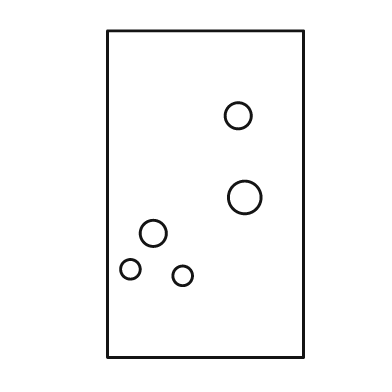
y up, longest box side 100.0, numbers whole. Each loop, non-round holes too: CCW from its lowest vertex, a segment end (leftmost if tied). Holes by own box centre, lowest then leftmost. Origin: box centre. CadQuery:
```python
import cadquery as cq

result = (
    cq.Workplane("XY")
    .moveTo(-30.0, -50.0)
    .lineTo(30.0, -50.0)
    .lineTo(30.0, 50.0)
    .lineTo(-30.0, 50.0)
    .close()
    .moveTo(-7.0, -25.0)
    .circle(3.0)
    .moveTo(-23.0, -23.0)
    .circle(3.0)
    .moveTo(-16.0, -12.0)
    .circle(4.0)
    .moveTo(12.0, -1.0)
    .circle(5.0)
    .moveTo(10.0, 24.0)
    .circle(4.0)
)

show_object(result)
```